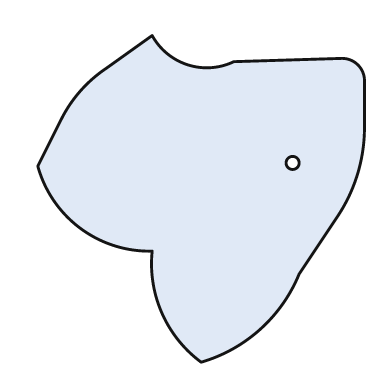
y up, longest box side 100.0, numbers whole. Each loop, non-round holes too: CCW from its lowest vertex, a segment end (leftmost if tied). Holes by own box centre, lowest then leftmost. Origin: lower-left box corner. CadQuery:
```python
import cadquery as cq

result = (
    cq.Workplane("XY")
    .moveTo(50.0, 0.0)
    .threePointArc((68.0, 10.0), (80.0, 27.0))
    .lineTo(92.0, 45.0)
    .threePointArc((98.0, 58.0), (100.0, 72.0))
    .lineTo(100.0, 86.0)
    .threePointArc((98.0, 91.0), (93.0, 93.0))
    .lineTo(60.0, 92.0)
    .threePointArc((46.0, 91.0), (35.0, 100.0))
    .lineTo(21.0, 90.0)
    .threePointArc((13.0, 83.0), (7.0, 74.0))
    .lineTo(0.0, 60.0)
    .threePointArc((13.0, 41.0), (35.0, 34.0))
    .threePointArc((38.0, 15.0), (50.0, 0.0))
    .close()
    .moveTo(78.0, 61.0)
    .circle(2.0)
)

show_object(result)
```